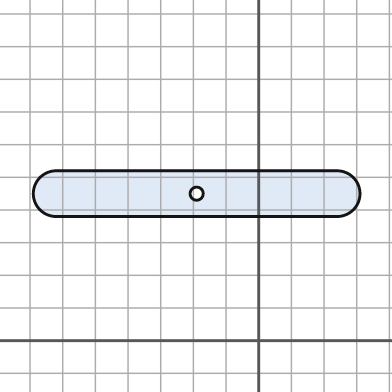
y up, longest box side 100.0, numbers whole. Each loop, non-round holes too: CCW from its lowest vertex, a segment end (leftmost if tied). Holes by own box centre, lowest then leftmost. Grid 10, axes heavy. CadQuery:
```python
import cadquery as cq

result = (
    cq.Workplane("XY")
    .moveTo(-62.0, 38.0)
    .lineTo(24.0, 38.0)
    .threePointArc((31.0, 45.0), (24.0, 52.0))
    .lineTo(-62.0, 52.0)
    .threePointArc((-69.0, 45.0), (-62.0, 38.0))
    .close()
    .moveTo(-19.0, 45.0)
    .circle(2.0)
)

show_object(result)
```